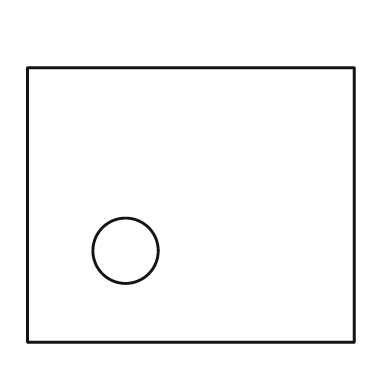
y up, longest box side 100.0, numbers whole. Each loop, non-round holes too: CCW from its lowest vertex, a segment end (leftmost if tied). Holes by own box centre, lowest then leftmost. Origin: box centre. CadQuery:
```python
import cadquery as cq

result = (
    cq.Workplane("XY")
    .moveTo(-50.0, -42.0)
    .lineTo(50.0, -42.0)
    .lineTo(50.0, 42.0)
    .lineTo(-50.0, 42.0)
    .close()
    .moveTo(-20.0, -14.0)
    .circle(10.0)
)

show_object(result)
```